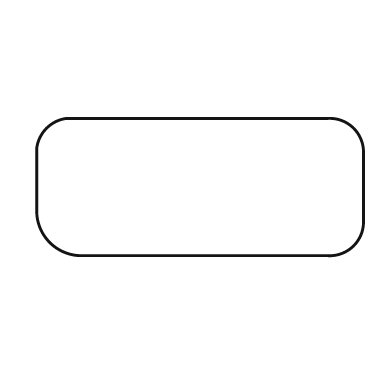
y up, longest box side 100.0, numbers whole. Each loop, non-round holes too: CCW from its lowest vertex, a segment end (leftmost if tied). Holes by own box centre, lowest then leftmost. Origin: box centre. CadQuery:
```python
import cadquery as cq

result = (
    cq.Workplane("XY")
    .moveTo(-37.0, -21.0)
    .lineTo(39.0, -21.0)
    .threePointArc((47.0, -18.0), (50.0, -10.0))
    .lineTo(50.0, 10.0)
    .threePointArc((47.0, 18.0), (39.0, 21.0))
    .lineTo(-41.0, 21.0)
    .threePointArc((-47.0, 18.0), (-50.0, 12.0))
    .lineTo(-50.0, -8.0)
    .threePointArc((-46.0, -17.0), (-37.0, -21.0))
    .close()
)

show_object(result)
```